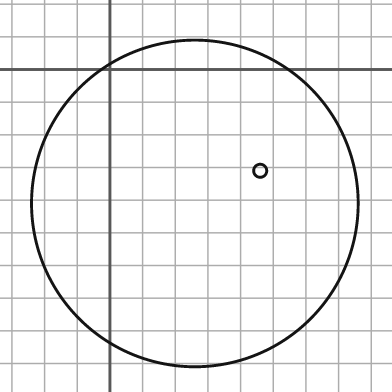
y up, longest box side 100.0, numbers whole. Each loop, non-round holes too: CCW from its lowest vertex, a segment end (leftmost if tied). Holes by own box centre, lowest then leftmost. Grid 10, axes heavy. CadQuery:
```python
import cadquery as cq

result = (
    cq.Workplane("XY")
    .moveTo(26.0, -41.0)
    .circle(50.0)
    .moveTo(46.0, -31.0)
    .circle(2.0)
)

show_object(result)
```